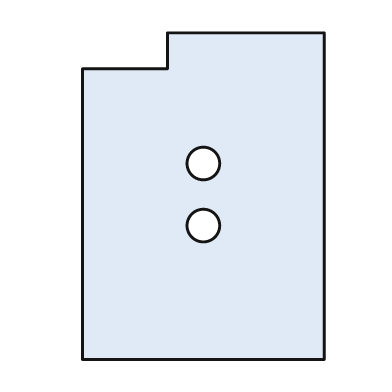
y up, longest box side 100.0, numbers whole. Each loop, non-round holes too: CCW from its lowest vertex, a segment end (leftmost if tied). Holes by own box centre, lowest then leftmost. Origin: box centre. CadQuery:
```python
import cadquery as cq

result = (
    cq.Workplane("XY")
    .moveTo(-37.0, -50.0)
    .lineTo(37.0, -50.0)
    .lineTo(37.0, 50.0)
    .lineTo(-11.0, 50.0)
    .lineTo(-11.0, 39.0)
    .lineTo(-37.0, 39.0)
    .close()
    .moveTo(0.0, -9.0)
    .circle(5.0)
    .moveTo(0.0, 10.0)
    .circle(5.0)
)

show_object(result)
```